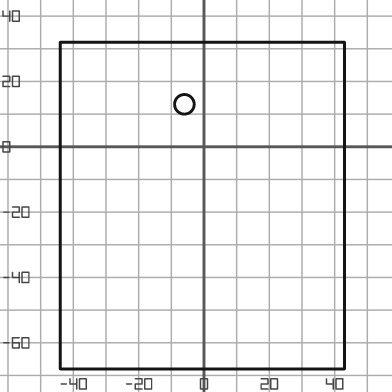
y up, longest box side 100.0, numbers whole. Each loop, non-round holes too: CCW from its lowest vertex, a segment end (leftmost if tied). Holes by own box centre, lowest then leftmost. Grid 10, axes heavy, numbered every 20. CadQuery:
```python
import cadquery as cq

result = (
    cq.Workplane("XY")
    .moveTo(-44.0, -68.0)
    .lineTo(43.0, -68.0)
    .lineTo(43.0, 32.0)
    .lineTo(-44.0, 32.0)
    .close()
    .moveTo(-6.0, 13.0)
    .circle(3.0)
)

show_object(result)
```